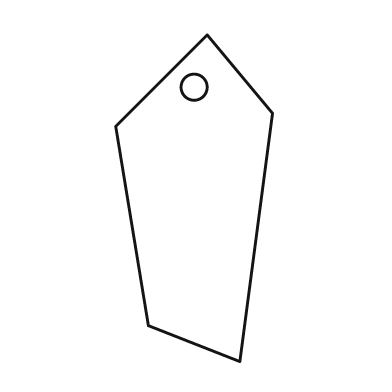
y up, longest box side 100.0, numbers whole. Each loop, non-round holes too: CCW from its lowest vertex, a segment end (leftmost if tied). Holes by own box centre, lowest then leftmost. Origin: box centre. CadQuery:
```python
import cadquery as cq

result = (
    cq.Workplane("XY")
    .moveTo(14.0, -50.0)
    .lineTo(24.0, 26.0)
    .lineTo(4.0, 50.0)
    .lineTo(-24.0, 22.0)
    .lineTo(-14.0, -39.0)
    .close()
    .moveTo(0.0, 34.0)
    .circle(4.0)
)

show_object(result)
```